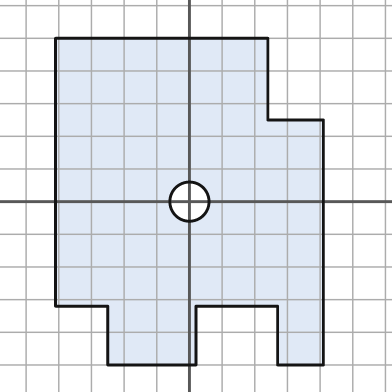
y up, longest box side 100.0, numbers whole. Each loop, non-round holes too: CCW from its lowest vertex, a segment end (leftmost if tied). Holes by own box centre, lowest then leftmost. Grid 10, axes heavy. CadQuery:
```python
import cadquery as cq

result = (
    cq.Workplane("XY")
    .moveTo(-25.0, -50.0)
    .lineTo(2.0, -50.0)
    .lineTo(2.0, -32.0)
    .lineTo(27.0, -32.0)
    .lineTo(27.0, -50.0)
    .lineTo(41.0, -50.0)
    .lineTo(41.0, 25.0)
    .lineTo(24.0, 25.0)
    .lineTo(24.0, 50.0)
    .lineTo(-41.0, 50.0)
    .lineTo(-41.0, -32.0)
    .lineTo(-25.0, -32.0)
    .close()
    .moveTo(0.0, 0.0)
    .circle(6.0)
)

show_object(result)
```